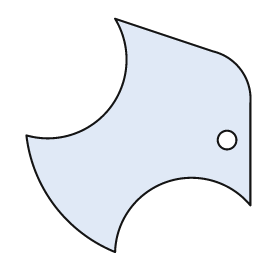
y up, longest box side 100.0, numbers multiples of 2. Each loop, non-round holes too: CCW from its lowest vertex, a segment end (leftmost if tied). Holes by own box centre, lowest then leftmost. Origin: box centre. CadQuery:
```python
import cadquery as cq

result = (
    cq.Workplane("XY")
    .moveTo(-10.0, -50.0)
    .threePointArc((12.0, -20.0), (48.0, -30.0))
    .lineTo(48.0, 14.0)
    .threePointArc((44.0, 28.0), (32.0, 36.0))
    .lineTo(-10.0, 50.0)
    .threePointArc((-12.0, 12.0), (-48.0, 0.0))
    .threePointArc((-36.0, -30.0), (-10.0, -50.0))
    .close()
    .moveTo(38.0, -2.0)
    .circle(4.0)
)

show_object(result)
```